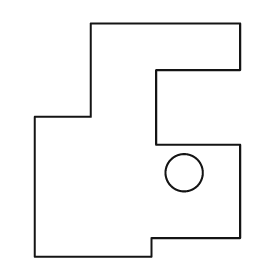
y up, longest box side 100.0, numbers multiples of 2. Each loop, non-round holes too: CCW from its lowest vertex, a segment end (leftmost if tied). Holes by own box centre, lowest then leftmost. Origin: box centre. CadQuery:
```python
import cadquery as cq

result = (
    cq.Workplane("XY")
    .moveTo(-44.0, -50.0)
    .lineTo(6.0, -50.0)
    .lineTo(6.0, -42.0)
    .lineTo(44.0, -42.0)
    .lineTo(44.0, -2.0)
    .lineTo(8.0, -2.0)
    .lineTo(8.0, 30.0)
    .lineTo(44.0, 30.0)
    .lineTo(44.0, 50.0)
    .lineTo(-20.0, 50.0)
    .lineTo(-20.0, 10.0)
    .lineTo(-44.0, 10.0)
    .close()
    .moveTo(20.0, -14.0)
    .circle(8.0)
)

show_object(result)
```